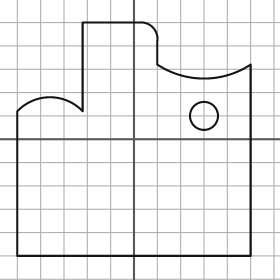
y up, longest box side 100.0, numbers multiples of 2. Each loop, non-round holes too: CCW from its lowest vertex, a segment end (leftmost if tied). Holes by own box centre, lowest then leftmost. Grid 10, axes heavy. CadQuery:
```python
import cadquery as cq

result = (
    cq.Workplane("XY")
    .moveTo(-50.0, -50.0)
    .lineTo(50.0, -50.0)
    .lineTo(50.0, 32.0)
    .threePointArc((30.0, 26.0), (10.0, 32.0))
    .lineTo(10.0, 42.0)
    .threePointArc((8.0, 48.0), (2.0, 50.0))
    .lineTo(-22.0, 50.0)
    .lineTo(-22.0, 12.0)
    .threePointArc((-36.0, 18.0), (-50.0, 12.0))
    .close()
    .moveTo(30.0, 10.0)
    .circle(6.0)
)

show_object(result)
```